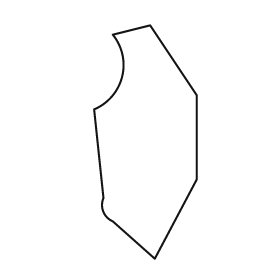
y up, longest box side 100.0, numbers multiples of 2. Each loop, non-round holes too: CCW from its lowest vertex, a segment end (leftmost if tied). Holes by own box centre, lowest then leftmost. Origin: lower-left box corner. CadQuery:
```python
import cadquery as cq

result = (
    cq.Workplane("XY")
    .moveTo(26.0, 0.0)
    .lineTo(44.0, 34.0)
    .lineTo(44.0, 70.0)
    .lineTo(24.0, 100.0)
    .lineTo(8.0, 96.0)
    .threePointArc((12.0, 78.0), (0.0, 64.0))
    .lineTo(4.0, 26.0)
    .threePointArc((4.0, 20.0), (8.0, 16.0))
    .close()
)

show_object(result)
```